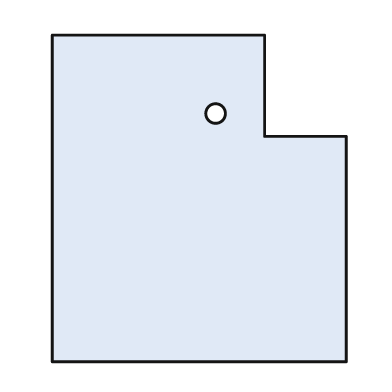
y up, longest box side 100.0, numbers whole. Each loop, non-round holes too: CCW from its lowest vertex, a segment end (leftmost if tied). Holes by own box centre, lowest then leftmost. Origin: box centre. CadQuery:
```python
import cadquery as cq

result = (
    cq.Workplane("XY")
    .moveTo(-45.0, -50.0)
    .lineTo(45.0, -50.0)
    .lineTo(45.0, 19.0)
    .lineTo(20.0, 19.0)
    .lineTo(20.0, 50.0)
    .lineTo(-45.0, 50.0)
    .close()
    .moveTo(5.0, 26.0)
    .circle(3.0)
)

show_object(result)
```